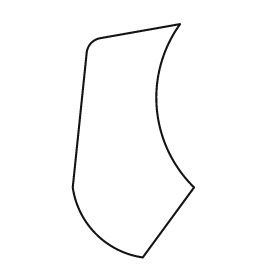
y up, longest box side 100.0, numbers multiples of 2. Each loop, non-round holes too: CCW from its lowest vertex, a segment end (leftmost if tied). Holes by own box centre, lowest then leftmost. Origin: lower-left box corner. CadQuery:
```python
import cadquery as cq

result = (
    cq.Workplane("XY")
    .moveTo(30.0, 0.0)
    .lineTo(52.0, 30.0)
    .threePointArc((36.0, 64.0), (46.0, 100.0))
    .lineTo(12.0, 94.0)
    .threePointArc((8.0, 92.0), (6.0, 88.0))
    .lineTo(0.0, 30.0)
    .threePointArc((10.0, 10.0), (30.0, 0.0))
    .close()
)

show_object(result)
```